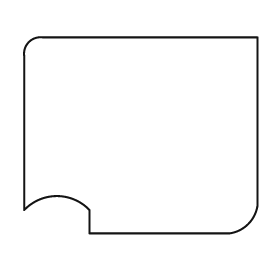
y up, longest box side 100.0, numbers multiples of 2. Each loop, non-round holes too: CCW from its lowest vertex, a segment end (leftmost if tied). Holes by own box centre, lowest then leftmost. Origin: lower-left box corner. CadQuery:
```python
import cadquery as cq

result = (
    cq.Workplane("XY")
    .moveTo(28.0, 0.0)
    .lineTo(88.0, 0.0)
    .threePointArc((96.0, 4.0), (100.0, 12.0))
    .lineTo(100.0, 84.0)
    .lineTo(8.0, 84.0)
    .threePointArc((2.0, 82.0), (0.0, 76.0))
    .lineTo(0.0, 10.0)
    .threePointArc((14.0, 16.0), (28.0, 10.0))
    .close()
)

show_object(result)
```